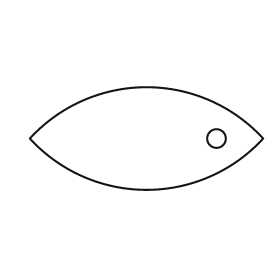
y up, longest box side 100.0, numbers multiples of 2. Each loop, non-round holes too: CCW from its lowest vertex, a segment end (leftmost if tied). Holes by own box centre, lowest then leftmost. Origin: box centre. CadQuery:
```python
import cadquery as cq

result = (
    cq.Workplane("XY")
    .moveTo(-50.0, 0.0)
    .threePointArc((0.0, -22.0), (50.0, 0.0))
    .threePointArc((0.0, 22.0), (-50.0, 0.0))
    .close()
    .moveTo(30.0, 0.0)
    .circle(4.0)
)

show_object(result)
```